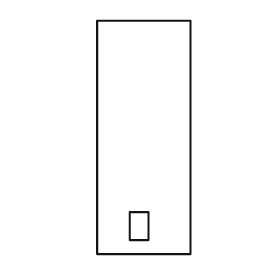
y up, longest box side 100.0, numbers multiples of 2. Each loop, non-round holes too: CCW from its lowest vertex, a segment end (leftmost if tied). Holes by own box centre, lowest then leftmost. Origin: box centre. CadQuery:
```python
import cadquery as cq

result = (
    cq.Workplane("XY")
    .moveTo(-20.0, -50.0)
    .lineTo(20.0, -50.0)
    .lineTo(20.0, 50.0)
    .lineTo(-20.0, 50.0)
    .close()
    .moveTo(-6.0, -44.0)
    .lineTo(2.0, -44.0)
    .lineTo(2.0, -32.0)
    .lineTo(-6.0, -32.0)
    .close()
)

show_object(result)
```